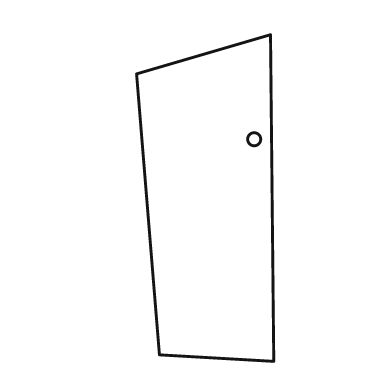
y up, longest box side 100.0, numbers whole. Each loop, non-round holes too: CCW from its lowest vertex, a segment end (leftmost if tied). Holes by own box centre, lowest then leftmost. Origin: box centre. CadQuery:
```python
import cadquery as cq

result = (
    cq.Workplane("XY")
    .moveTo(21.0, -50.0)
    .lineTo(20.0, 50.0)
    .lineTo(-21.0, 38.0)
    .lineTo(-14.0, -48.0)
    .close()
    .moveTo(15.0, 18.0)
    .circle(2.0)
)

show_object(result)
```